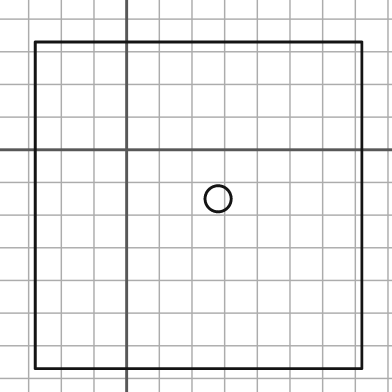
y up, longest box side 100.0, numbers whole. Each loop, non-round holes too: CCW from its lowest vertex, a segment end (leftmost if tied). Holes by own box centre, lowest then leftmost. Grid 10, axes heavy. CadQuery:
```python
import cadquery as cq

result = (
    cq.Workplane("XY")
    .moveTo(-28.0, -67.0)
    .lineTo(72.0, -67.0)
    .lineTo(72.0, 33.0)
    .lineTo(-28.0, 33.0)
    .close()
    .moveTo(28.0, -15.0)
    .circle(4.0)
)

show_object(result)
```